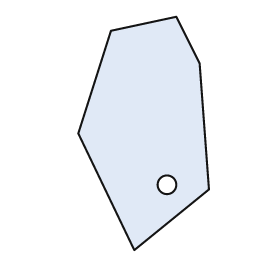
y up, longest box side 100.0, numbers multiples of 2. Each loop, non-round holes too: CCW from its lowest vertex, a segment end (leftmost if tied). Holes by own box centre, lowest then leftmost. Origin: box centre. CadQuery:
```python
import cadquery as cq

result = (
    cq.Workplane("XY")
    .moveTo(-4.0, -50.0)
    .lineTo(28.0, -24.0)
    .lineTo(24.0, 30.0)
    .lineTo(14.0, 50.0)
    .lineTo(-14.0, 44.0)
    .lineTo(-28.0, 0.0)
    .close()
    .moveTo(10.0, -22.0)
    .circle(4.0)
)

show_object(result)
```